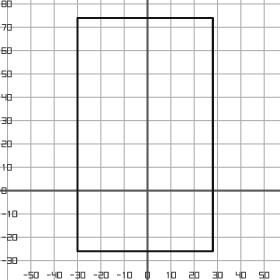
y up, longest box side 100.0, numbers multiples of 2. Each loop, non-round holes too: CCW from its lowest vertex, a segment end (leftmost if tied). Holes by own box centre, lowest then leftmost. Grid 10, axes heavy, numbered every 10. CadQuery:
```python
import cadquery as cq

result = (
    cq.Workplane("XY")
    .moveTo(-30.0, -26.0)
    .lineTo(28.0, -26.0)
    .lineTo(28.0, 74.0)
    .lineTo(-30.0, 74.0)
    .close()
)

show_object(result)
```